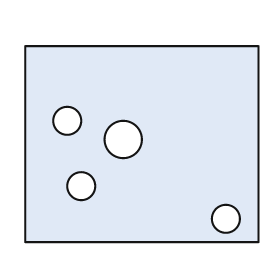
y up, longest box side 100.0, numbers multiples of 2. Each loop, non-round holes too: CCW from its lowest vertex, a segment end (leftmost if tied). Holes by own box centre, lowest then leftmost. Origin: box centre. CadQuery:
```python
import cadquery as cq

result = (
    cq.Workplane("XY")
    .moveTo(-50.0, -42.0)
    .lineTo(50.0, -42.0)
    .lineTo(50.0, 42.0)
    .lineTo(-50.0, 42.0)
    .close()
    .moveTo(36.0, -32.0)
    .circle(6.0)
    .moveTo(-26.0, -18.0)
    .circle(6.0)
    .moveTo(-8.0, 2.0)
    .circle(8.0)
    .moveTo(-32.0, 10.0)
    .circle(6.0)
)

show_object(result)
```